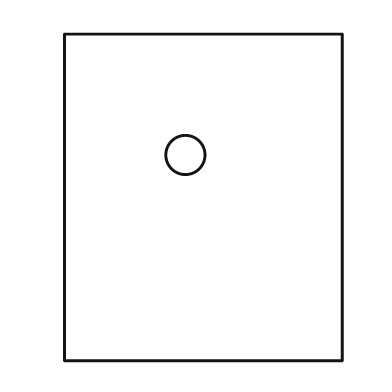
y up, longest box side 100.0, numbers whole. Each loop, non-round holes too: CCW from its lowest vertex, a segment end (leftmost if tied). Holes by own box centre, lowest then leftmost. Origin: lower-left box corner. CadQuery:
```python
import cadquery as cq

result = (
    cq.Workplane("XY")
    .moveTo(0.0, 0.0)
    .lineTo(85.0, 0.0)
    .lineTo(85.0, 100.0)
    .lineTo(0.0, 100.0)
    .close()
    .moveTo(37.0, 63.0)
    .circle(6.0)
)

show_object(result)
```